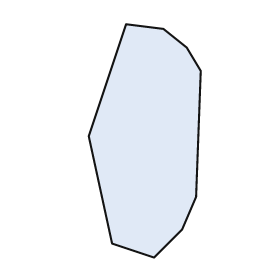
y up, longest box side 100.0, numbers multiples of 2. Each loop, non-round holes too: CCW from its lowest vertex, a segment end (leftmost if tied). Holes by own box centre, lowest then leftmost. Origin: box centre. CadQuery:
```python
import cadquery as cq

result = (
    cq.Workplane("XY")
    .moveTo(4.0, -50.0)
    .lineTo(16.0, -38.0)
    .lineTo(22.0, -24.0)
    .lineTo(24.0, 30.0)
    .lineTo(18.0, 40.0)
    .lineTo(8.0, 48.0)
    .lineTo(-8.0, 50.0)
    .lineTo(-24.0, 2.0)
    .lineTo(-14.0, -44.0)
    .close()
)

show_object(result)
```